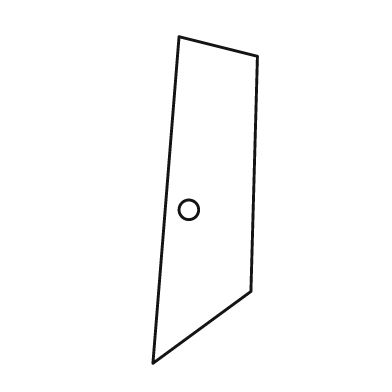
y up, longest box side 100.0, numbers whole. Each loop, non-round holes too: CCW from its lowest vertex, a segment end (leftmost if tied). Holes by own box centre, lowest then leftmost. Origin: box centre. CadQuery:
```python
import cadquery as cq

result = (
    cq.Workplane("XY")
    .moveTo(-16.0, -50.0)
    .lineTo(14.0, -28.0)
    .lineTo(16.0, 44.0)
    .lineTo(-8.0, 50.0)
    .close()
    .moveTo(-5.0, -3.0)
    .circle(3.0)
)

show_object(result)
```